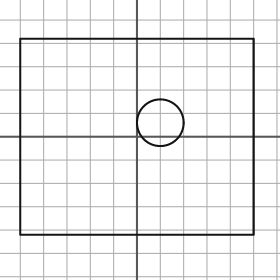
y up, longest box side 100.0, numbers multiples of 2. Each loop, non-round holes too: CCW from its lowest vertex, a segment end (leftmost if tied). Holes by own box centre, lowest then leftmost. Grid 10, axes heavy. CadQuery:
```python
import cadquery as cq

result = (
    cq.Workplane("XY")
    .moveTo(-50.0, -42.0)
    .lineTo(50.0, -42.0)
    .lineTo(50.0, 42.0)
    .lineTo(-50.0, 42.0)
    .close()
    .moveTo(10.0, 6.0)
    .circle(10.0)
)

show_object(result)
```